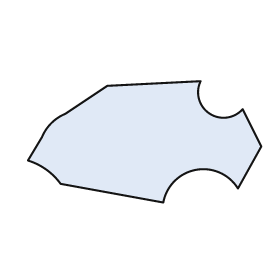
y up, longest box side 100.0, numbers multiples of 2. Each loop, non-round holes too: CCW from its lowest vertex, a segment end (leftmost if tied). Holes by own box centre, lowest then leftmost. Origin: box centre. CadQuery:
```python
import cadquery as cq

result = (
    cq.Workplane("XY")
    .moveTo(8.0, -26.0)
    .threePointArc((22.0, -12.0), (40.0, -20.0))
    .lineTo(50.0, -2.0)
    .lineTo(42.0, 14.0)
    .threePointArc((28.0, 12.0), (24.0, 26.0))
    .lineTo(-16.0, 24.0)
    .lineTo(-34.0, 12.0)
    .threePointArc((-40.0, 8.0), (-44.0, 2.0))
    .lineTo(-50.0, -8.0)
    .threePointArc((-42.0, -12.0), (-36.0, -18.0))
    .close()
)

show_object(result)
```